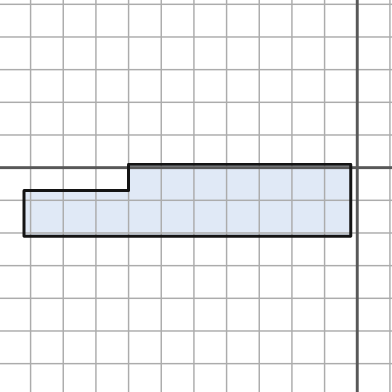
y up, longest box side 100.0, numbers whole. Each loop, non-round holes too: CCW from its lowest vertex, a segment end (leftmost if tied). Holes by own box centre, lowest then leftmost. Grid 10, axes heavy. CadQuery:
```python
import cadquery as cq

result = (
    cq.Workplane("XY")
    .moveTo(-102.0, -21.0)
    .lineTo(-2.0, -21.0)
    .lineTo(-2.0, 1.0)
    .lineTo(-70.0, 1.0)
    .lineTo(-70.0, -7.0)
    .lineTo(-102.0, -7.0)
    .close()
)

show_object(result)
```